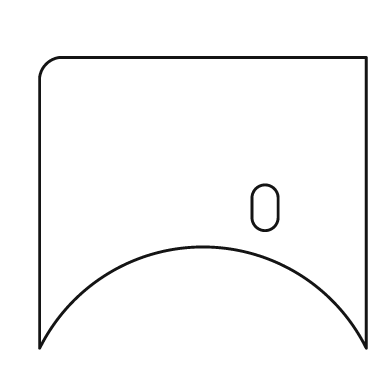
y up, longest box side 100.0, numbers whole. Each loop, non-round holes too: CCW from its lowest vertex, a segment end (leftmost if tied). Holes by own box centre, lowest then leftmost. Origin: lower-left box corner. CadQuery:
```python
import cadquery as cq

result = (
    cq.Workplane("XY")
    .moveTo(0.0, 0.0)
    .threePointArc((50.0, 31.0), (100.0, 0.0))
    .lineTo(100.0, 89.0)
    .lineTo(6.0, 89.0)
    .threePointArc((2.0, 87.0), (0.0, 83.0))
    .close()
    .moveTo(65.0, 40.0)
    .threePointArc((69.0, 36.0), (73.0, 40.0))
    .lineTo(73.0, 46.0)
    .threePointArc((69.0, 50.0), (65.0, 46.0))
    .close()
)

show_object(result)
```